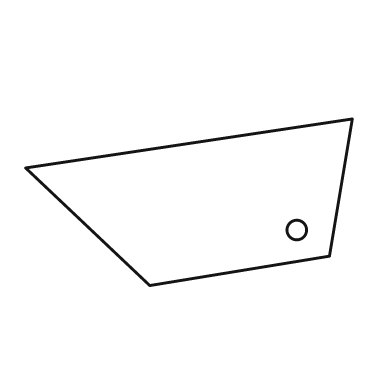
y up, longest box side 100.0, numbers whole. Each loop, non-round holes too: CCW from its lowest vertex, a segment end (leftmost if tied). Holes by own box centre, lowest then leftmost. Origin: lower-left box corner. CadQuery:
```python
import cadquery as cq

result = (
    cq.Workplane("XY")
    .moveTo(38.0, 0.0)
    .lineTo(93.0, 9.0)
    .lineTo(100.0, 51.0)
    .lineTo(0.0, 36.0)
    .close()
    .moveTo(83.0, 17.0)
    .circle(3.0)
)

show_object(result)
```